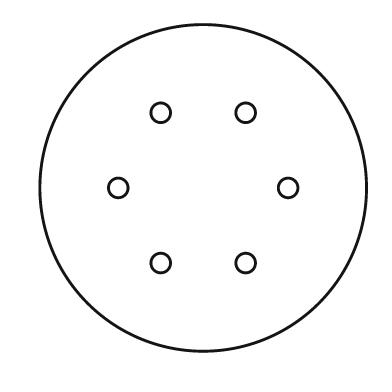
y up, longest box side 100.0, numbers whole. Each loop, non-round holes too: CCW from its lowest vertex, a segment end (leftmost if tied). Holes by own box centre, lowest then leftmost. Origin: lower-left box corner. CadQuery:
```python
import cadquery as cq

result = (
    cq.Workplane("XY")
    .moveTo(50.0, 50.0)
    .circle(50.0)
    .moveTo(37.0, 27.0)
    .circle(3.0)
    .moveTo(63.0, 27.0)
    .circle(3.0)
    .moveTo(24.0, 50.0)
    .circle(3.0)
    .moveTo(76.0, 50.0)
    .circle(3.0)
    .moveTo(37.0, 73.0)
    .circle(3.0)
    .moveTo(63.0, 73.0)
    .circle(3.0)
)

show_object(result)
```